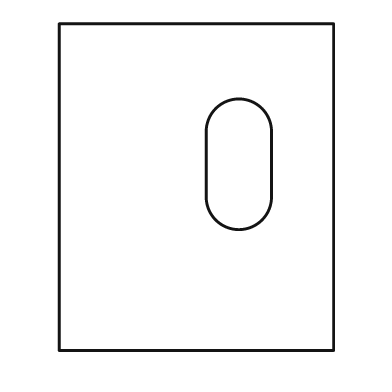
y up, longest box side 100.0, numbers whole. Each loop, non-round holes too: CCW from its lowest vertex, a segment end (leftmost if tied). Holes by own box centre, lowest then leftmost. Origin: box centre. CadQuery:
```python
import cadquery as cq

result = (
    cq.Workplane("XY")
    .moveTo(-42.0, -50.0)
    .lineTo(42.0, -50.0)
    .lineTo(42.0, 50.0)
    .lineTo(-42.0, 50.0)
    .close()
    .moveTo(3.0, -3.0)
    .threePointArc((13.0, -13.0), (23.0, -3.0))
    .lineTo(23.0, 17.0)
    .threePointArc((13.0, 27.0), (3.0, 17.0))
    .close()
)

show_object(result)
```